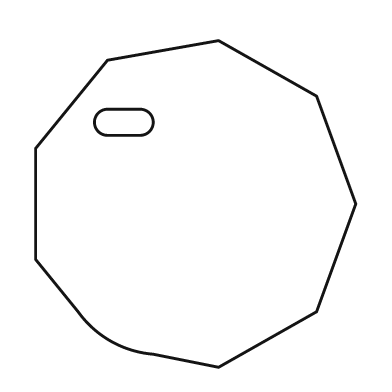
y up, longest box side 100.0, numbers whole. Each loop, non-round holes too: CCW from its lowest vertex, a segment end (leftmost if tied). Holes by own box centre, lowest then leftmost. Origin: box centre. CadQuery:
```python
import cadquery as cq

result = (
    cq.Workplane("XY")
    .moveTo(7.0, -50.0)
    .lineTo(37.0, -33.0)
    .lineTo(49.0, 0.0)
    .lineTo(37.0, 33.0)
    .lineTo(7.0, 50.0)
    .lineTo(-27.0, 44.0)
    .lineTo(-49.0, 17.0)
    .lineTo(-49.0, -17.0)
    .lineTo(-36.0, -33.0)
    .threePointArc((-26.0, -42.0), (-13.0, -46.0))
    .close()
    .moveTo(-27.0, 21.0)
    .lineTo(-17.0, 21.0)
    .threePointArc((-13.0, 25.0), (-17.0, 29.0))
    .lineTo(-27.0, 29.0)
    .threePointArc((-31.0, 25.0), (-27.0, 21.0))
    .close()
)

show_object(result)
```